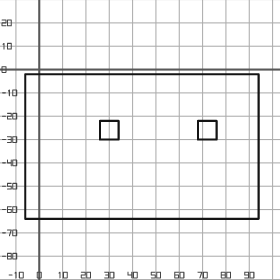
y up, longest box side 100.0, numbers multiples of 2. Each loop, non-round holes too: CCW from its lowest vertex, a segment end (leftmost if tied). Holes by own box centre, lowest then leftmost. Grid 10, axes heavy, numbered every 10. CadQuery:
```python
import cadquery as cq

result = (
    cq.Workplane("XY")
    .moveTo(-6.0, -64.0)
    .lineTo(94.0, -64.0)
    .lineTo(94.0, -2.0)
    .lineTo(-6.0, -2.0)
    .close()
    .moveTo(26.0, -30.0)
    .lineTo(34.0, -30.0)
    .lineTo(34.0, -22.0)
    .lineTo(26.0, -22.0)
    .close()
    .moveTo(68.0, -30.0)
    .lineTo(76.0, -30.0)
    .lineTo(76.0, -22.0)
    .lineTo(68.0, -22.0)
    .close()
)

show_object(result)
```